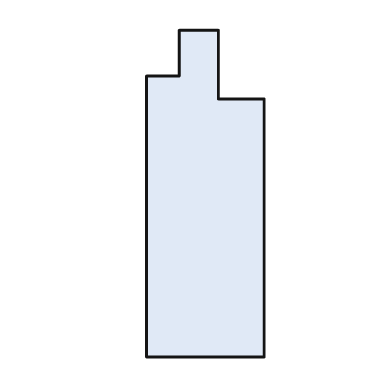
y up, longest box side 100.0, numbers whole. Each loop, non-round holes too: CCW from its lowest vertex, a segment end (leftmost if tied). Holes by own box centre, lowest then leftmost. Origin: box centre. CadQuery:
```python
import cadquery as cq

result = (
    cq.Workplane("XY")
    .moveTo(-18.0, -50.0)
    .lineTo(18.0, -50.0)
    .lineTo(18.0, 29.0)
    .lineTo(4.0, 29.0)
    .lineTo(4.0, 50.0)
    .lineTo(-8.0, 50.0)
    .lineTo(-8.0, 36.0)
    .lineTo(-18.0, 36.0)
    .close()
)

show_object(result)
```